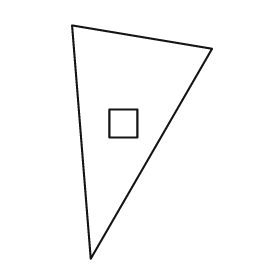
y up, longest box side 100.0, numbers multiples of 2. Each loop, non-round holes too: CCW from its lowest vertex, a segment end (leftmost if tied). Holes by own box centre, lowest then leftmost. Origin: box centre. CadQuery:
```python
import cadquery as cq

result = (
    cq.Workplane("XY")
    .moveTo(-22.0, -50.0)
    .lineTo(30.0, 40.0)
    .lineTo(-30.0, 50.0)
    .close()
    .moveTo(-14.0, 2.0)
    .lineTo(-2.0, 2.0)
    .lineTo(-2.0, 14.0)
    .lineTo(-14.0, 14.0)
    .close()
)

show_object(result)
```